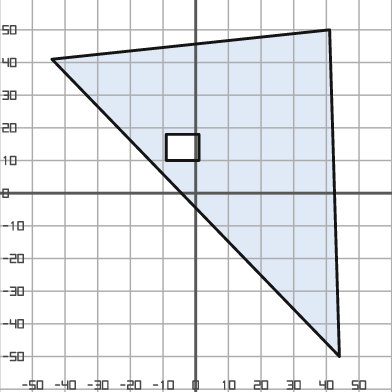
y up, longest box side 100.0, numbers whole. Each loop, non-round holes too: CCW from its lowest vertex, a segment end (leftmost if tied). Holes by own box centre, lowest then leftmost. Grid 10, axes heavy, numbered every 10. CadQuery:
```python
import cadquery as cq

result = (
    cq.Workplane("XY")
    .moveTo(44.0, -50.0)
    .lineTo(41.0, 50.0)
    .lineTo(-44.0, 41.0)
    .close()
    .moveTo(-9.0, 10.0)
    .lineTo(1.0, 10.0)
    .lineTo(1.0, 18.0)
    .lineTo(-9.0, 18.0)
    .close()
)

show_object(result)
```